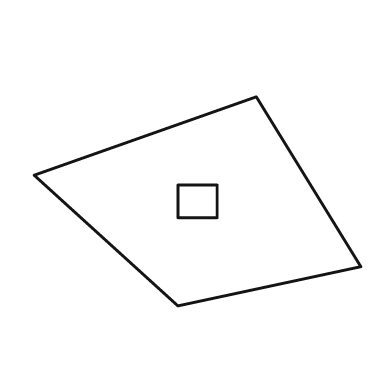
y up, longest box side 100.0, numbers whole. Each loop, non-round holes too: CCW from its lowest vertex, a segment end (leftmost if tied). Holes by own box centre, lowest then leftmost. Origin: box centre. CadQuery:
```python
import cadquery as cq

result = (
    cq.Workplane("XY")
    .moveTo(-6.0, -32.0)
    .lineTo(50.0, -20.0)
    .lineTo(18.0, 32.0)
    .lineTo(-50.0, 8.0)
    .close()
    .moveTo(-6.0, -5.0)
    .lineTo(6.0, -5.0)
    .lineTo(6.0, 5.0)
    .lineTo(-6.0, 5.0)
    .close()
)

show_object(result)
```